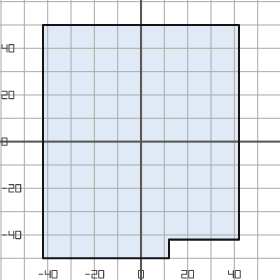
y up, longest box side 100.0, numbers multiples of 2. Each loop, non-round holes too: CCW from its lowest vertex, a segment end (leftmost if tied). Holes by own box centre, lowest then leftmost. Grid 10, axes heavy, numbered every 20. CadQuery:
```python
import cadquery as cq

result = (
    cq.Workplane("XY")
    .moveTo(-42.0, -50.0)
    .lineTo(12.0, -50.0)
    .lineTo(12.0, -42.0)
    .lineTo(42.0, -42.0)
    .lineTo(42.0, 50.0)
    .lineTo(-42.0, 50.0)
    .close()
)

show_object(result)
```